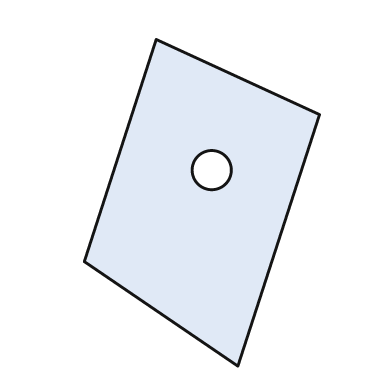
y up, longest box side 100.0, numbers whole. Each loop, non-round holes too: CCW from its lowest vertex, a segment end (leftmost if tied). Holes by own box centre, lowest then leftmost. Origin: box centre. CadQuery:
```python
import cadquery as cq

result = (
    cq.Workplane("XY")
    .moveTo(11.0, -50.0)
    .lineTo(36.0, 27.0)
    .lineTo(-14.0, 50.0)
    .lineTo(-36.0, -18.0)
    .close()
    .moveTo(3.0, 10.0)
    .circle(6.0)
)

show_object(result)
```